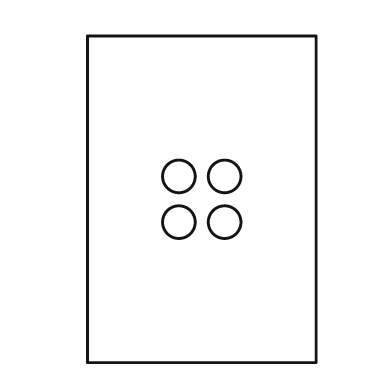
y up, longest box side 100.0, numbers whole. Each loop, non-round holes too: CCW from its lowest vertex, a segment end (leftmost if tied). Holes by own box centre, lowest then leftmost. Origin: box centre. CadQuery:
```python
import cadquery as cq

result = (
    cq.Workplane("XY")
    .moveTo(-35.0, -50.0)
    .lineTo(35.0, -50.0)
    .lineTo(35.0, 50.0)
    .lineTo(-35.0, 50.0)
    .close()
    .moveTo(-7.0, -7.0)
    .circle(5.0)
    .moveTo(7.0, -7.0)
    .circle(5.0)
    .moveTo(-7.0, 7.0)
    .circle(5.0)
    .moveTo(7.0, 7.0)
    .circle(5.0)
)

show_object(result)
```